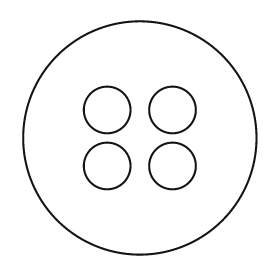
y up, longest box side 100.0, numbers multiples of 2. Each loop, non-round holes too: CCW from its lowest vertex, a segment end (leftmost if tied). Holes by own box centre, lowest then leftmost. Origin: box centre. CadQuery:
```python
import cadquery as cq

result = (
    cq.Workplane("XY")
    .moveTo(0.0, 0.0)
    .circle(50.0)
    .moveTo(-14.0, -12.0)
    .circle(10.0)
    .moveTo(14.0, -12.0)
    .circle(10.0)
    .moveTo(-14.0, 12.0)
    .circle(10.0)
    .moveTo(14.0, 12.0)
    .circle(10.0)
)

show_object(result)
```